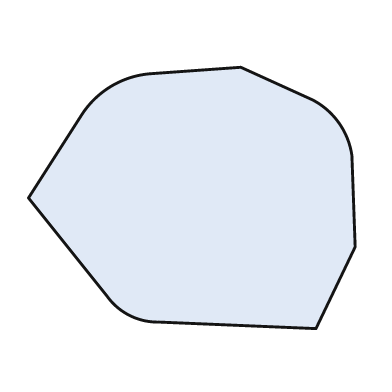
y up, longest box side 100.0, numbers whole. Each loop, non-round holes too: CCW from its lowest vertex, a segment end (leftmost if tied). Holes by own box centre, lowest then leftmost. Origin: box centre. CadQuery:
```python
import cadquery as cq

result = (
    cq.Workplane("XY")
    .moveTo(38.0, -40.0)
    .lineTo(50.0, -15.0)
    .lineTo(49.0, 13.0)
    .threePointArc((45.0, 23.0), (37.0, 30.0))
    .lineTo(15.0, 40.0)
    .lineTo(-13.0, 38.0)
    .threePointArc((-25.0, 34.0), (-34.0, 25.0))
    .lineTo(-50.0, 0.0)
    .lineTo(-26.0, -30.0)
    .threePointArc((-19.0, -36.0), (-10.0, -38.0))
    .close()
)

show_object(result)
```